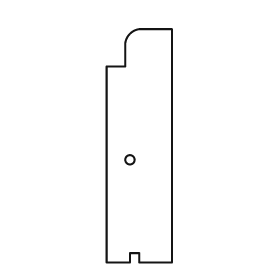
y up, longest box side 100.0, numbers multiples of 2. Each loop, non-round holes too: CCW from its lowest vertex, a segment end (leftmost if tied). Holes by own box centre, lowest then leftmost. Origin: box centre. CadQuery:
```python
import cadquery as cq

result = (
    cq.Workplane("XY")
    .moveTo(-14.0, -50.0)
    .lineTo(-4.0, -50.0)
    .lineTo(-4.0, -46.0)
    .lineTo(0.0, -46.0)
    .lineTo(0.0, -50.0)
    .lineTo(14.0, -50.0)
    .lineTo(14.0, 50.0)
    .lineTo(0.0, 50.0)
    .threePointArc((-4.0, 48.0), (-6.0, 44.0))
    .lineTo(-6.0, 34.0)
    .lineTo(-14.0, 34.0)
    .close()
    .moveTo(-4.0, -6.0)
    .circle(2.0)
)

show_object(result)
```